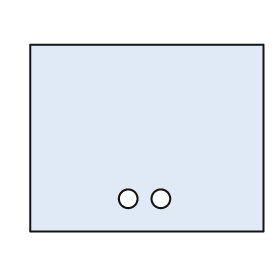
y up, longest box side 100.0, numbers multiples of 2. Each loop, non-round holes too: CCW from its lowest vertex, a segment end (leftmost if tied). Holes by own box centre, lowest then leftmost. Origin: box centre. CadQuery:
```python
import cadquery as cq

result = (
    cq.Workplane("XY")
    .moveTo(-50.0, -40.0)
    .lineTo(50.0, -40.0)
    .lineTo(50.0, 40.0)
    .lineTo(-50.0, 40.0)
    .close()
    .moveTo(-8.0, -26.0)
    .circle(4.0)
    .moveTo(6.0, -26.0)
    .circle(4.0)
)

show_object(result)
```